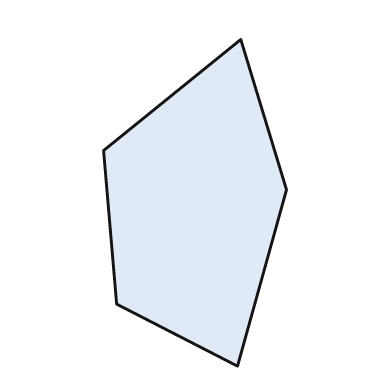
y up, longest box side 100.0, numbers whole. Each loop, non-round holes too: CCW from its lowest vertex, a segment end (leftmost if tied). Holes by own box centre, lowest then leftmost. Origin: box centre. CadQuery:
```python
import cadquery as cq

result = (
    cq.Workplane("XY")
    .moveTo(13.0, -50.0)
    .lineTo(28.0, 4.0)
    .lineTo(14.0, 50.0)
    .lineTo(-28.0, 16.0)
    .lineTo(-24.0, -31.0)
    .close()
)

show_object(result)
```